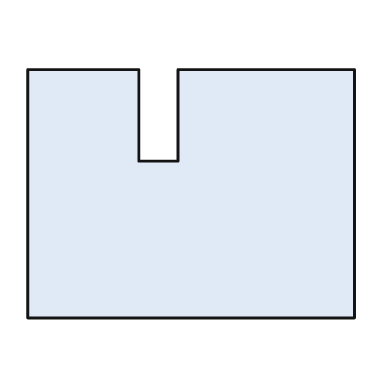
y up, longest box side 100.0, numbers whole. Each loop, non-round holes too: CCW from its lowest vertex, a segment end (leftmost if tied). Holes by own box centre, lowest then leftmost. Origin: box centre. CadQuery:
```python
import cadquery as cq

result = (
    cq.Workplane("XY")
    .moveTo(-50.0, -38.0)
    .lineTo(50.0, -38.0)
    .lineTo(50.0, 38.0)
    .lineTo(-4.0, 38.0)
    .lineTo(-4.0, 10.0)
    .lineTo(-16.0, 10.0)
    .lineTo(-16.0, 38.0)
    .lineTo(-50.0, 38.0)
    .close()
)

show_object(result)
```